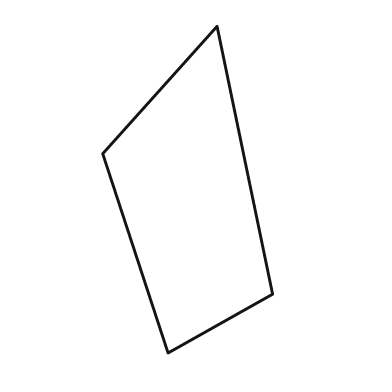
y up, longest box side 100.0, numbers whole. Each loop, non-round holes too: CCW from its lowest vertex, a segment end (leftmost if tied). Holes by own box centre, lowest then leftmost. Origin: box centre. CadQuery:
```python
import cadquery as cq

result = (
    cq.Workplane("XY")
    .moveTo(-6.0, -50.0)
    .lineTo(26.0, -32.0)
    .lineTo(9.0, 50.0)
    .lineTo(-26.0, 11.0)
    .close()
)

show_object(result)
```